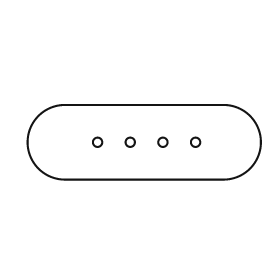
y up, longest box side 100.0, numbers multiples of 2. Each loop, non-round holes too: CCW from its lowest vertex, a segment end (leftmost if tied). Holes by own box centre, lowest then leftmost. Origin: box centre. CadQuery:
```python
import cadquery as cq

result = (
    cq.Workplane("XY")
    .moveTo(-34.0, -16.0)
    .lineTo(34.0, -16.0)
    .threePointArc((50.0, 0.0), (34.0, 16.0))
    .lineTo(-34.0, 16.0)
    .threePointArc((-50.0, 0.0), (-34.0, -16.0))
    .close()
    .moveTo(-20.0, 0.0)
    .circle(2.0)
    .moveTo(-6.0, 0.0)
    .circle(2.0)
    .moveTo(8.0, 0.0)
    .circle(2.0)
    .moveTo(22.0, 0.0)
    .circle(2.0)
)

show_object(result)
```